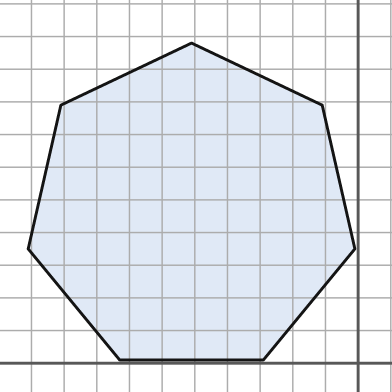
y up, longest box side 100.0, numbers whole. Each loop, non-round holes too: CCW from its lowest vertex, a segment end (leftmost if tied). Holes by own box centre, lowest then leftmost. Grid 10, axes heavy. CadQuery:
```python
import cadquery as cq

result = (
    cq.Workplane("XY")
    .moveTo(-73.0, 1.0)
    .lineTo(-29.0, 1.0)
    .lineTo(-1.0, 35.0)
    .lineTo(-11.0, 79.0)
    .lineTo(-51.0, 98.0)
    .lineTo(-91.0, 79.0)
    .lineTo(-101.0, 35.0)
    .close()
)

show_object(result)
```